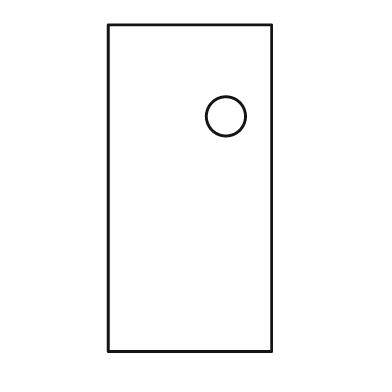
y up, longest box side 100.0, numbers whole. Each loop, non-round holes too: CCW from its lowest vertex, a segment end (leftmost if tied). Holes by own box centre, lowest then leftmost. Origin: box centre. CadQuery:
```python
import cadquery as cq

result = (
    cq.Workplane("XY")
    .moveTo(-25.0, -50.0)
    .lineTo(25.0, -50.0)
    .lineTo(25.0, 50.0)
    .lineTo(-25.0, 50.0)
    .close()
    .moveTo(11.0, 22.0)
    .circle(6.0)
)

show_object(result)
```